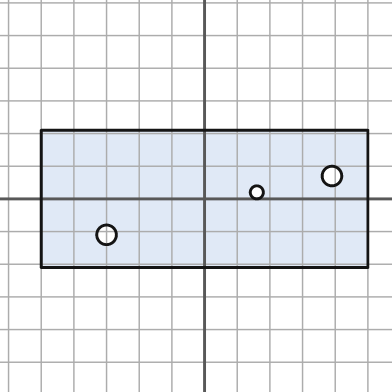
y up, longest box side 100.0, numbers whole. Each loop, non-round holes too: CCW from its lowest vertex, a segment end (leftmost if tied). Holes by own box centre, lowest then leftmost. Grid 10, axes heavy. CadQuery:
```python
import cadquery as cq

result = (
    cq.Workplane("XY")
    .moveTo(-50.0, -21.0)
    .lineTo(50.0, -21.0)
    .lineTo(50.0, 21.0)
    .lineTo(-50.0, 21.0)
    .close()
    .moveTo(-30.0, -11.0)
    .circle(3.0)
    .moveTo(16.0, 2.0)
    .circle(2.0)
    .moveTo(39.0, 7.0)
    .circle(3.0)
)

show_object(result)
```